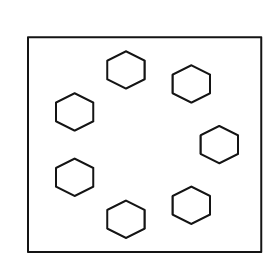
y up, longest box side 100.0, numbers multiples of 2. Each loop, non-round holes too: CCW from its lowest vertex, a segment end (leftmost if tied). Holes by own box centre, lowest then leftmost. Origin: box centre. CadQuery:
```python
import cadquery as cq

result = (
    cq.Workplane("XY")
    .moveTo(-50.0, -46.0)
    .lineTo(50.0, -46.0)
    .lineTo(50.0, 46.0)
    .lineTo(-50.0, 46.0)
    .close()
    .moveTo(-8.0, -40.0)
    .lineTo(0.0, -36.0)
    .lineTo(0.0, -28.0)
    .lineTo(-8.0, -24.0)
    .lineTo(-16.0, -28.0)
    .lineTo(-16.0, -36.0)
    .close()
    .moveTo(20.0, -34.0)
    .lineTo(28.0, -30.0)
    .lineTo(28.0, -22.0)
    .lineTo(20.0, -18.0)
    .lineTo(12.0, -22.0)
    .lineTo(12.0, -30.0)
    .close()
    .moveTo(-30.0, -22.0)
    .lineTo(-22.0, -18.0)
    .lineTo(-22.0, -10.0)
    .lineTo(-30.0, -6.0)
    .lineTo(-38.0, -10.0)
    .lineTo(-38.0, -18.0)
    .close()
    .moveTo(32.0, -8.0)
    .lineTo(40.0, -4.0)
    .lineTo(40.0, 4.0)
    .lineTo(32.0, 8.0)
    .lineTo(24.0, 4.0)
    .lineTo(24.0, -4.0)
    .close()
    .moveTo(-30.0, 6.0)
    .lineTo(-22.0, 10.0)
    .lineTo(-22.0, 18.0)
    .lineTo(-30.0, 22.0)
    .lineTo(-38.0, 18.0)
    .lineTo(-38.0, 10.0)
    .close()
    .moveTo(20.0, 18.0)
    .lineTo(28.0, 22.0)
    .lineTo(28.0, 30.0)
    .lineTo(20.0, 34.0)
    .lineTo(12.0, 30.0)
    .lineTo(12.0, 22.0)
    .close()
    .moveTo(-8.0, 24.0)
    .lineTo(0.0, 28.0)
    .lineTo(0.0, 36.0)
    .lineTo(-8.0, 40.0)
    .lineTo(-16.0, 36.0)
    .lineTo(-16.0, 28.0)
    .close()
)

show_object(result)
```